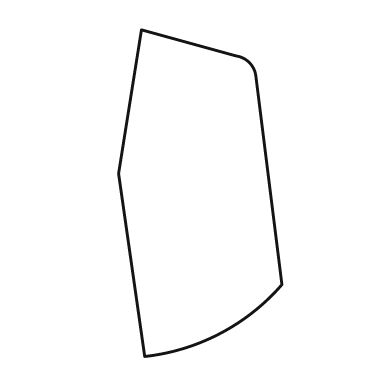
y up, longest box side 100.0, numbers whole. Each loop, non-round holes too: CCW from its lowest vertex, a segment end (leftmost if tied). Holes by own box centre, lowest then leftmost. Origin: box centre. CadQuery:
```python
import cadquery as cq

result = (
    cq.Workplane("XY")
    .moveTo(-17.0, -50.0)
    .threePointArc((6.0, -43.0), (25.0, -28.0))
    .lineTo(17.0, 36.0)
    .threePointArc((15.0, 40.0), (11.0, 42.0))
    .lineTo(-18.0, 50.0)
    .lineTo(-25.0, 6.0)
    .close()
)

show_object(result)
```